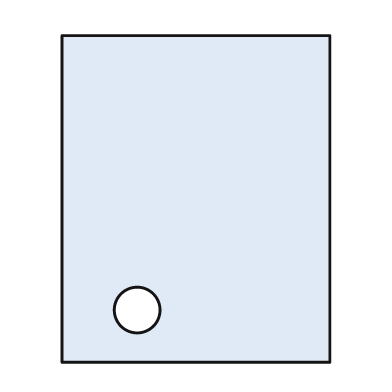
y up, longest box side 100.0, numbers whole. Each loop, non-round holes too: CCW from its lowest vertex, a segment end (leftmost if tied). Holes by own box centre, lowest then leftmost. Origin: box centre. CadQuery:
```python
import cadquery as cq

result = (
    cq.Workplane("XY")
    .moveTo(-41.0, -50.0)
    .lineTo(41.0, -50.0)
    .lineTo(41.0, 50.0)
    .lineTo(-41.0, 50.0)
    .close()
    .moveTo(-18.0, -34.0)
    .circle(7.0)
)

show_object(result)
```